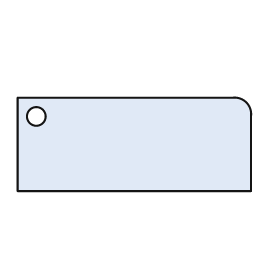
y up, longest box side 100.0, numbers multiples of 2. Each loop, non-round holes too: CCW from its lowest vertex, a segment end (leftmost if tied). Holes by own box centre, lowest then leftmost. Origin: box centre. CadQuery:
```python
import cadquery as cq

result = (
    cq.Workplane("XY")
    .moveTo(-50.0, -20.0)
    .lineTo(50.0, -20.0)
    .lineTo(50.0, 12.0)
    .threePointArc((48.0, 18.0), (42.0, 20.0))
    .lineTo(-50.0, 20.0)
    .close()
    .moveTo(-42.0, 12.0)
    .circle(4.0)
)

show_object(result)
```